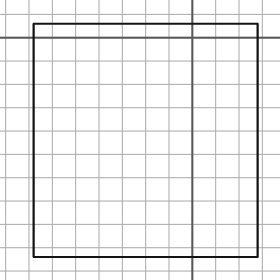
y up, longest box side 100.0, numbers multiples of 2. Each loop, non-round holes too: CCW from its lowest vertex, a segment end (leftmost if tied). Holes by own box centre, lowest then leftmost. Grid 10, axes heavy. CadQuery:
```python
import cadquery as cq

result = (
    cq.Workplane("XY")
    .moveTo(-68.0, -94.0)
    .lineTo(28.0, -94.0)
    .lineTo(28.0, 6.0)
    .lineTo(-68.0, 6.0)
    .close()
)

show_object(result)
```